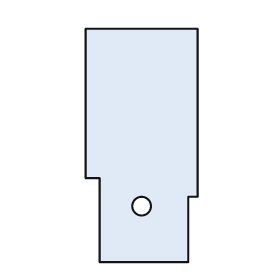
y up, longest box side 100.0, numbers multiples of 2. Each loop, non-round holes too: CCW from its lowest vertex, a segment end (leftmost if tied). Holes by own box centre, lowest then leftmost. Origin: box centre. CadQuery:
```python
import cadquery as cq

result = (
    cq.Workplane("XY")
    .moveTo(-18.0, -50.0)
    .lineTo(20.0, -50.0)
    .lineTo(20.0, -22.0)
    .lineTo(24.0, -22.0)
    .lineTo(24.0, 50.0)
    .lineTo(-24.0, 50.0)
    .lineTo(-24.0, -14.0)
    .lineTo(-18.0, -14.0)
    .close()
    .moveTo(0.0, -26.0)
    .circle(4.0)
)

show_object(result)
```